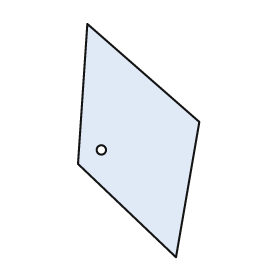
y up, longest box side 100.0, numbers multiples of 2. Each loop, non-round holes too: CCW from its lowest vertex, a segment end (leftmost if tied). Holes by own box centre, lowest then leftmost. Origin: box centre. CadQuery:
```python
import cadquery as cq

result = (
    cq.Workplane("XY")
    .moveTo(16.0, -50.0)
    .lineTo(26.0, 8.0)
    .lineTo(-22.0, 50.0)
    .lineTo(-26.0, -10.0)
    .close()
    .moveTo(-16.0, -4.0)
    .circle(2.0)
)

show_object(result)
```